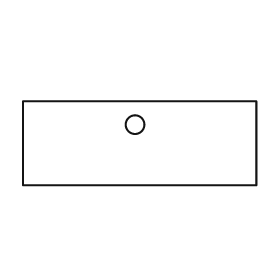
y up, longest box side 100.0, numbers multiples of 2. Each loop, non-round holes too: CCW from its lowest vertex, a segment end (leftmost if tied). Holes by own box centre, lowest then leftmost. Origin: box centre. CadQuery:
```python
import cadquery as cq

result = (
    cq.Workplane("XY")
    .moveTo(-50.0, -18.0)
    .lineTo(50.0, -18.0)
    .lineTo(50.0, 18.0)
    .lineTo(-50.0, 18.0)
    .close()
    .moveTo(-2.0, 8.0)
    .circle(4.0)
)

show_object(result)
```